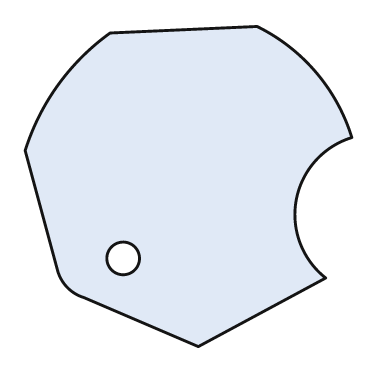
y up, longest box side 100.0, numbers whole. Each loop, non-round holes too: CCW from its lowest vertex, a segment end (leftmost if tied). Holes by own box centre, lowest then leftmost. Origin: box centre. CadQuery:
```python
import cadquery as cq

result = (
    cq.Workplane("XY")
    .moveTo(3.0, -49.0)
    .lineTo(42.0, -28.0)
    .threePointArc((33.0, -4.0), (50.0, 15.0))
    .threePointArc((39.0, 35.0), (21.0, 49.0))
    .lineTo(-24.0, 47.0)
    .threePointArc((-40.0, 31.0), (-50.0, 11.0))
    .lineTo(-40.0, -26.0)
    .threePointArc((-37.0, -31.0), (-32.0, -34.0))
    .close()
    .moveTo(-20.0, -22.0)
    .circle(5.0)
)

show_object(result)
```